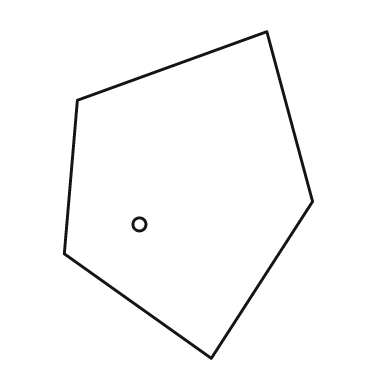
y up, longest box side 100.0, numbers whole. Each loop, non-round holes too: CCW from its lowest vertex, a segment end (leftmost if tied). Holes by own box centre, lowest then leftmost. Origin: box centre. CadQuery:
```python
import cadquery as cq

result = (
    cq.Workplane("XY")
    .moveTo(7.0, -50.0)
    .lineTo(38.0, -2.0)
    .lineTo(24.0, 50.0)
    .lineTo(-34.0, 29.0)
    .lineTo(-38.0, -18.0)
    .close()
    .moveTo(-15.0, -9.0)
    .circle(2.0)
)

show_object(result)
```